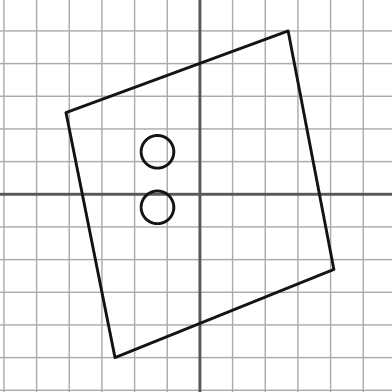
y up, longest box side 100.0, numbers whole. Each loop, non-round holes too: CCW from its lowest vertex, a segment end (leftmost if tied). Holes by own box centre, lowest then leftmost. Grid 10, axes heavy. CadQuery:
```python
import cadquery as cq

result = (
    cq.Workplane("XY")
    .moveTo(-26.0, -50.0)
    .lineTo(41.0, -23.0)
    .lineTo(27.0, 50.0)
    .lineTo(-41.0, 25.0)
    .close()
    .moveTo(-13.0, -4.0)
    .circle(5.0)
    .moveTo(-13.0, 13.0)
    .circle(5.0)
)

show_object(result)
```